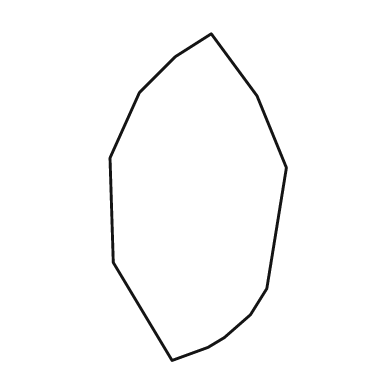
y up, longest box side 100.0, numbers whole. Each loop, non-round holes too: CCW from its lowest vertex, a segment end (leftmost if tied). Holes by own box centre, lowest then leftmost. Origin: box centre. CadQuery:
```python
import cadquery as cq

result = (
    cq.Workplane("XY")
    .moveTo(-8.0, -50.0)
    .lineTo(3.0, -46.0)
    .lineTo(8.0, -43.0)
    .lineTo(16.0, -36.0)
    .lineTo(21.0, -28.0)
    .lineTo(27.0, 9.0)
    .lineTo(18.0, 31.0)
    .lineTo(4.0, 50.0)
    .lineTo(-7.0, 43.0)
    .lineTo(-18.0, 32.0)
    .lineTo(-27.0, 12.0)
    .lineTo(-26.0, -20.0)
    .close()
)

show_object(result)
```